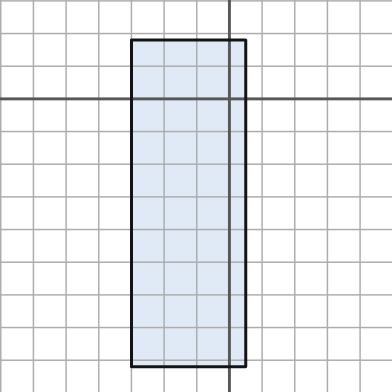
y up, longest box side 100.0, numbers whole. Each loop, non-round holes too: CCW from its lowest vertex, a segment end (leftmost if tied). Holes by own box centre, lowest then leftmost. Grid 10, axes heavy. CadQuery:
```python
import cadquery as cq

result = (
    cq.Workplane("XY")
    .moveTo(-30.0, -82.0)
    .lineTo(5.0, -82.0)
    .lineTo(5.0, 18.0)
    .lineTo(-30.0, 18.0)
    .close()
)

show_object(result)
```